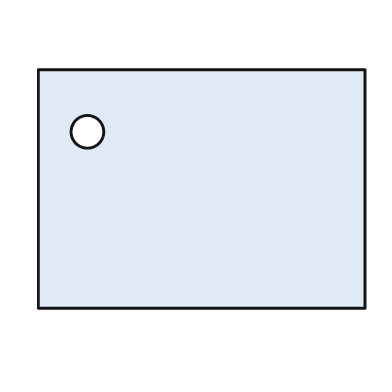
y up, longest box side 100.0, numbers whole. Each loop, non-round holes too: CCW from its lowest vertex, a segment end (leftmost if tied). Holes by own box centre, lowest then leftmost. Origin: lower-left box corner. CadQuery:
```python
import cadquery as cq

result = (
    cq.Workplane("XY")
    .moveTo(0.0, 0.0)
    .lineTo(100.0, 0.0)
    .lineTo(100.0, 73.0)
    .lineTo(0.0, 73.0)
    .close()
    .moveTo(15.0, 54.0)
    .circle(5.0)
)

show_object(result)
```